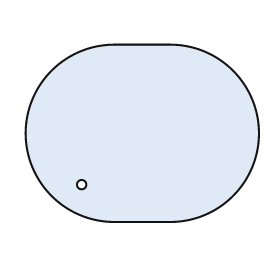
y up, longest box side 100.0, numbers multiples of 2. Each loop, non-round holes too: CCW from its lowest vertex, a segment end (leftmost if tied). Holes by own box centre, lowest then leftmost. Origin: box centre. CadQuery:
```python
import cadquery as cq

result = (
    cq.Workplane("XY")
    .moveTo(-12.0, -38.0)
    .lineTo(12.0, -38.0)
    .threePointArc((50.0, 0.0), (12.0, 38.0))
    .lineTo(-12.0, 38.0)
    .threePointArc((-50.0, 0.0), (-12.0, -38.0))
    .close()
    .moveTo(-26.0, -22.0)
    .circle(2.0)
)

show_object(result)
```